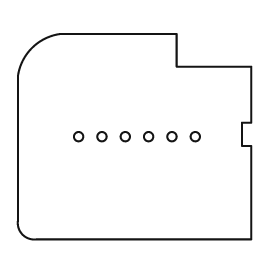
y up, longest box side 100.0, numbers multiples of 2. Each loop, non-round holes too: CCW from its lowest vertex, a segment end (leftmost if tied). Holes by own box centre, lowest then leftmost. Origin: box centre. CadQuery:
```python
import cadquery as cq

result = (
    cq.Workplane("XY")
    .moveTo(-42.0, -44.0)
    .lineTo(50.0, -44.0)
    .lineTo(50.0, -4.0)
    .lineTo(46.0, -4.0)
    .lineTo(46.0, 6.0)
    .lineTo(50.0, 6.0)
    .lineTo(50.0, 30.0)
    .lineTo(18.0, 30.0)
    .lineTo(18.0, 44.0)
    .lineTo(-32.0, 44.0)
    .threePointArc((-44.0, 38.0), (-50.0, 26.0))
    .lineTo(-50.0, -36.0)
    .threePointArc((-48.0, -42.0), (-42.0, -44.0))
    .close()
    .moveTo(-24.0, 0.0)
    .circle(2.0)
    .moveTo(-14.0, 0.0)
    .circle(2.0)
    .moveTo(-4.0, 0.0)
    .circle(2.0)
    .moveTo(6.0, 0.0)
    .circle(2.0)
    .moveTo(16.0, 0.0)
    .circle(2.0)
    .moveTo(26.0, 0.0)
    .circle(2.0)
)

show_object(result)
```